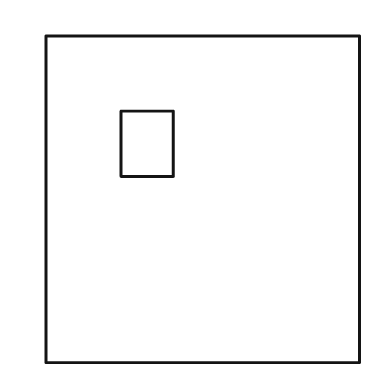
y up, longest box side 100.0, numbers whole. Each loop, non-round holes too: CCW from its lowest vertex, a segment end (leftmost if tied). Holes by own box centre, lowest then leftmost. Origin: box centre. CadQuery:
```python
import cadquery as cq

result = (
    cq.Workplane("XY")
    .moveTo(-48.0, -50.0)
    .lineTo(48.0, -50.0)
    .lineTo(48.0, 50.0)
    .lineTo(-48.0, 50.0)
    .close()
    .moveTo(-25.0, 7.0)
    .lineTo(-9.0, 7.0)
    .lineTo(-9.0, 27.0)
    .lineTo(-25.0, 27.0)
    .close()
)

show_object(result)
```